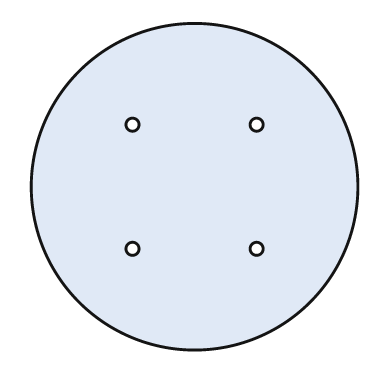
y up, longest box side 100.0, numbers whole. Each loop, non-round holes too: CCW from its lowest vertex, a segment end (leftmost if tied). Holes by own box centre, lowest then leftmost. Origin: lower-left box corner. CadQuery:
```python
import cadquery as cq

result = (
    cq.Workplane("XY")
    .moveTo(50.0, 50.0)
    .circle(50.0)
    .moveTo(31.0, 31.0)
    .circle(2.0)
    .moveTo(69.0, 31.0)
    .circle(2.0)
    .moveTo(31.0, 69.0)
    .circle(2.0)
    .moveTo(69.0, 69.0)
    .circle(2.0)
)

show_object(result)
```